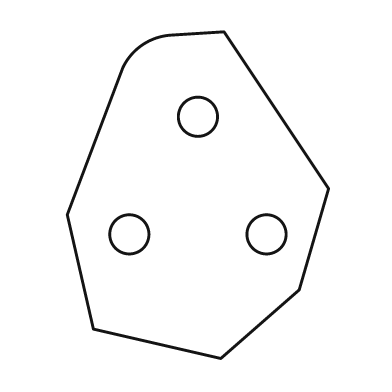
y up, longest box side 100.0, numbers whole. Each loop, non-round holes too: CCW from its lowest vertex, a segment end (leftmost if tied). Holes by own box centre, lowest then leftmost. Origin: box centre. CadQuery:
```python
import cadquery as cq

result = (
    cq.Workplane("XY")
    .moveTo(7.0, -50.0)
    .lineTo(31.0, -29.0)
    .lineTo(40.0, 2.0)
    .lineTo(8.0, 50.0)
    .lineTo(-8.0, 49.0)
    .threePointArc((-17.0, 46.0), (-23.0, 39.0))
    .lineTo(-40.0, -6.0)
    .lineTo(-32.0, -41.0)
    .close()
    .moveTo(-21.0, -12.0)
    .circle(6.0)
    .moveTo(21.0, -12.0)
    .circle(6.0)
    .moveTo(0.0, 24.0)
    .circle(6.0)
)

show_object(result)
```